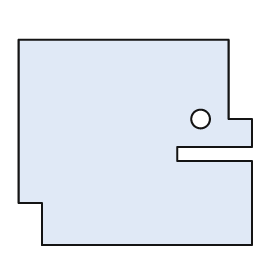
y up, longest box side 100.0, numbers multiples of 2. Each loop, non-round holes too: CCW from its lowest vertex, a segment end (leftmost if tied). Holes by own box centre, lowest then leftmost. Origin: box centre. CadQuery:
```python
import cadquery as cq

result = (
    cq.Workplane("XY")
    .moveTo(-40.0, -44.0)
    .lineTo(50.0, -44.0)
    .lineTo(50.0, -8.0)
    .lineTo(18.0, -8.0)
    .lineTo(18.0, -2.0)
    .lineTo(50.0, -2.0)
    .lineTo(50.0, 10.0)
    .lineTo(40.0, 10.0)
    .lineTo(40.0, 44.0)
    .lineTo(-50.0, 44.0)
    .lineTo(-50.0, -26.0)
    .lineTo(-40.0, -26.0)
    .close()
    .moveTo(28.0, 10.0)
    .circle(4.0)
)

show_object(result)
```